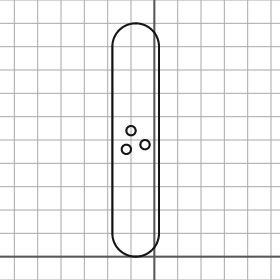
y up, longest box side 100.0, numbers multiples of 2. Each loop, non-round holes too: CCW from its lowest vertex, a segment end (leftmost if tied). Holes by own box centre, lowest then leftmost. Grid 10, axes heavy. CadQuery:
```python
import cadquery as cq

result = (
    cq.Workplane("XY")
    .moveTo(-18.0, 10.0)
    .threePointArc((-8.0, 0.0), (2.0, 10.0))
    .lineTo(2.0, 90.0)
    .threePointArc((-8.0, 100.0), (-18.0, 90.0))
    .close()
    .moveTo(-12.0, 46.0)
    .circle(2.0)
    .moveTo(-4.0, 48.0)
    .circle(2.0)
    .moveTo(-10.0, 54.0)
    .circle(2.0)
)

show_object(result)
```